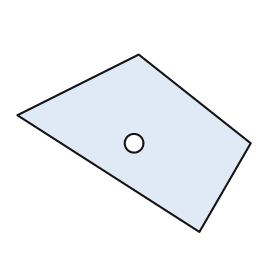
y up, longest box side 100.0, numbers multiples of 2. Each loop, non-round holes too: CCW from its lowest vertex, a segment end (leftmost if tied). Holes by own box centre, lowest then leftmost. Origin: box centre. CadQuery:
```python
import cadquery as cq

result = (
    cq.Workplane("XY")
    .moveTo(28.0, -38.0)
    .lineTo(50.0, 0.0)
    .lineTo(2.0, 38.0)
    .lineTo(-50.0, 12.0)
    .close()
    .moveTo(0.0, 0.0)
    .circle(4.0)
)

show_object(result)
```